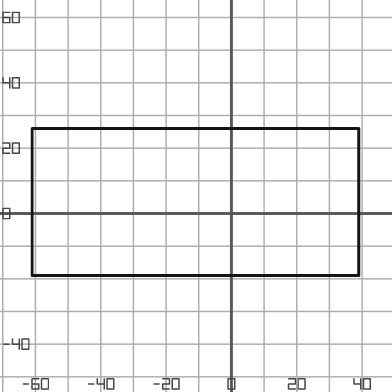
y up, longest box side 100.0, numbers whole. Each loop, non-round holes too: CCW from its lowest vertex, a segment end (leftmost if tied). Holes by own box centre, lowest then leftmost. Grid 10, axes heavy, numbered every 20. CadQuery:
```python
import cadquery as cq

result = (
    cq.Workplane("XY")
    .moveTo(-61.0, -19.0)
    .lineTo(39.0, -19.0)
    .lineTo(39.0, 26.0)
    .lineTo(-61.0, 26.0)
    .close()
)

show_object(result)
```